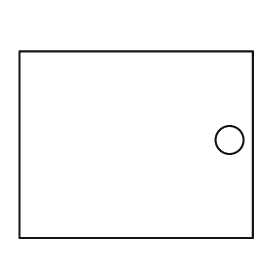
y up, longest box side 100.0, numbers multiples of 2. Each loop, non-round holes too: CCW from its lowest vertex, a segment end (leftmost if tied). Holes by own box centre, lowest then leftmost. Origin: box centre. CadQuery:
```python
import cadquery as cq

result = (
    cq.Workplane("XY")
    .moveTo(-50.0, -40.0)
    .lineTo(50.0, -40.0)
    .lineTo(50.0, 40.0)
    .lineTo(-50.0, 40.0)
    .close()
    .moveTo(40.0, 2.0)
    .circle(6.0)
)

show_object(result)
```